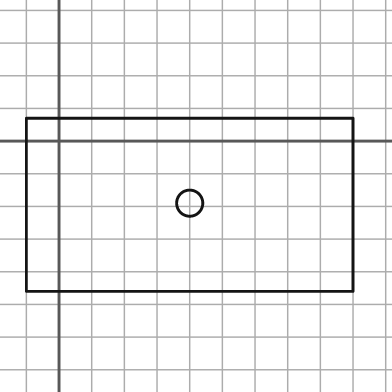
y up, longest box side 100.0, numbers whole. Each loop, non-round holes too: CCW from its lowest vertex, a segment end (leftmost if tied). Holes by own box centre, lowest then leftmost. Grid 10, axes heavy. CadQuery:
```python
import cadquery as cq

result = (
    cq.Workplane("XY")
    .moveTo(-10.0, -46.0)
    .lineTo(90.0, -46.0)
    .lineTo(90.0, 7.0)
    .lineTo(-10.0, 7.0)
    .close()
    .moveTo(40.0, -19.0)
    .circle(4.0)
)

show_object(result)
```